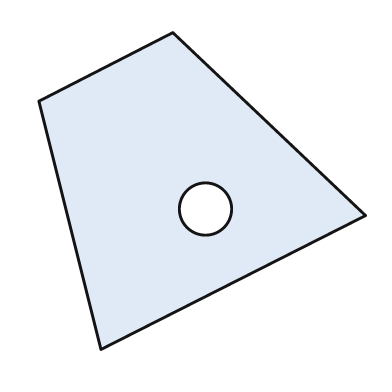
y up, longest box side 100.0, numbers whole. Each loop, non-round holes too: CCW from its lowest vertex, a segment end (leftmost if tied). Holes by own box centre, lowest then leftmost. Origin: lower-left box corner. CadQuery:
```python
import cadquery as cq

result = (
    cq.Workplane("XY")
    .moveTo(19.0, 0.0)
    .lineTo(100.0, 41.0)
    .lineTo(41.0, 97.0)
    .lineTo(0.0, 76.0)
    .close()
    .moveTo(51.0, 43.0)
    .circle(8.0)
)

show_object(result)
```